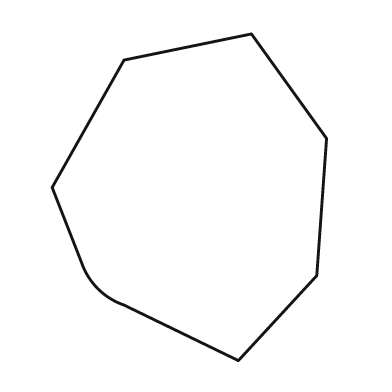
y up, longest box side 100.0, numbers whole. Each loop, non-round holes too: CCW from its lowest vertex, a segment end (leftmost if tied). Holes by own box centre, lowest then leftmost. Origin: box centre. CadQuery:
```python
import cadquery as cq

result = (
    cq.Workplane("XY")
    .moveTo(15.0, -50.0)
    .lineTo(39.0, -24.0)
    .lineTo(42.0, 18.0)
    .lineTo(19.0, 50.0)
    .lineTo(-20.0, 42.0)
    .lineTo(-42.0, 3.0)
    .lineTo(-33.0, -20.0)
    .threePointArc((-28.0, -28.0), (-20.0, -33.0))
    .close()
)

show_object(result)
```